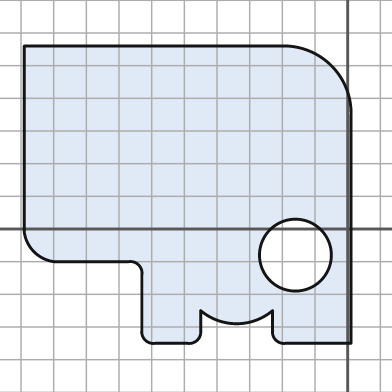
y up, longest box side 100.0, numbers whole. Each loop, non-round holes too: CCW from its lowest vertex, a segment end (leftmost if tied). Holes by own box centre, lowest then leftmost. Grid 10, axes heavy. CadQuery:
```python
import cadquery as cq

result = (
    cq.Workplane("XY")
    .moveTo(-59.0, -35.0)
    .lineTo(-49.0, -35.0)
    .threePointArc((-46.0, -34.0), (-45.0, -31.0))
    .lineTo(-45.0, -25.0)
    .threePointArc((-34.0, -29.0), (-23.0, -25.0))
    .lineTo(-23.0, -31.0)
    .threePointArc((-22.0, -34.0), (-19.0, -35.0))
    .lineTo(1.0, -35.0)
    .lineTo(1.0, 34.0)
    .threePointArc((-5.0, 50.0), (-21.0, 56.0))
    .lineTo(-99.0, 56.0)
    .lineTo(-99.0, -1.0)
    .threePointArc((-96.0, -7.0), (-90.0, -10.0))
    .lineTo(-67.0, -10.0)
    .threePointArc((-64.0, -11.0), (-63.0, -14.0))
    .lineTo(-63.0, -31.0)
    .threePointArc((-62.0, -34.0), (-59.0, -35.0))
    .close()
    .moveTo(-16.0, -8.0)
    .circle(11.0)
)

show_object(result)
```